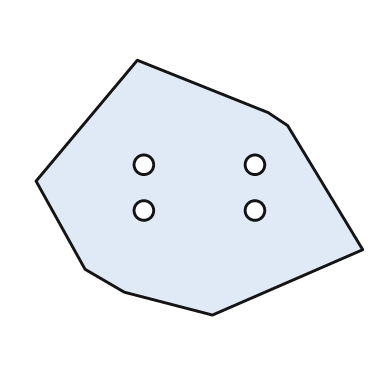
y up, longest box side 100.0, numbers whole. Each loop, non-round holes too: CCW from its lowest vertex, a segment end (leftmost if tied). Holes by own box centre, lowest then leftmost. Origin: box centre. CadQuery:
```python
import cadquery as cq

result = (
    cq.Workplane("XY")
    .moveTo(4.0, -39.0)
    .lineTo(50.0, -19.0)
    .lineTo(27.0, 19.0)
    .lineTo(21.0, 23.0)
    .lineTo(-19.0, 39.0)
    .lineTo(-50.0, 2.0)
    .lineTo(-35.0, -25.0)
    .lineTo(-23.0, -32.0)
    .close()
    .moveTo(-17.0, -7.0)
    .circle(3.0)
    .moveTo(17.0, -7.0)
    .circle(3.0)
    .moveTo(-17.0, 7.0)
    .circle(3.0)
    .moveTo(17.0, 7.0)
    .circle(3.0)
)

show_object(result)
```